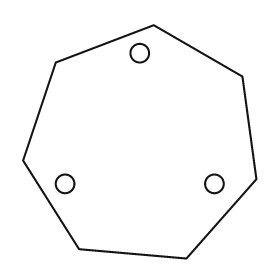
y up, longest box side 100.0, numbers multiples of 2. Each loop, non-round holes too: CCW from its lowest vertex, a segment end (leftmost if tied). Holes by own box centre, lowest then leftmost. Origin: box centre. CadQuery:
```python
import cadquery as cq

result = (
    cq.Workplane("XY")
    .moveTo(20.0, -50.0)
    .lineTo(50.0, -16.0)
    .lineTo(44.0, 28.0)
    .lineTo(6.0, 50.0)
    .lineTo(-36.0, 34.0)
    .lineTo(-50.0, -8.0)
    .lineTo(-26.0, -46.0)
    .close()
    .moveTo(-32.0, -18.0)
    .circle(4.0)
    .moveTo(32.0, -18.0)
    .circle(4.0)
    .moveTo(0.0, 38.0)
    .circle(4.0)
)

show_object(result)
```